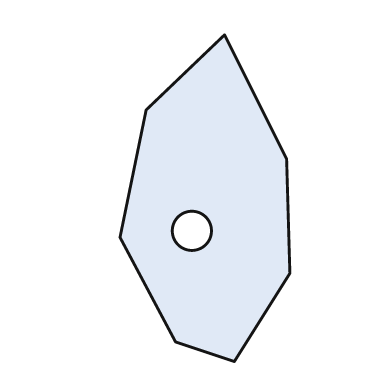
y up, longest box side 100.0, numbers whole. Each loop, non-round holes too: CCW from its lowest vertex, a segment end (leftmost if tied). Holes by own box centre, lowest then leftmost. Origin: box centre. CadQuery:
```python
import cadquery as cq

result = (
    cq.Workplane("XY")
    .moveTo(9.0, -50.0)
    .lineTo(26.0, -23.0)
    .lineTo(25.0, 12.0)
    .lineTo(6.0, 50.0)
    .lineTo(-18.0, 27.0)
    .lineTo(-26.0, -12.0)
    .lineTo(-9.0, -44.0)
    .close()
    .moveTo(-4.0, -10.0)
    .circle(6.0)
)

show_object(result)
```